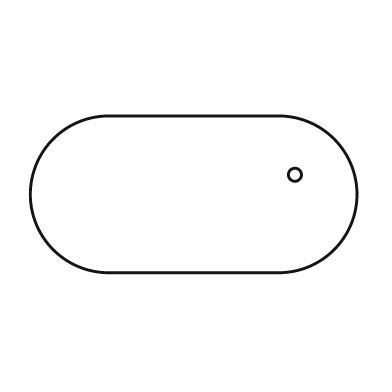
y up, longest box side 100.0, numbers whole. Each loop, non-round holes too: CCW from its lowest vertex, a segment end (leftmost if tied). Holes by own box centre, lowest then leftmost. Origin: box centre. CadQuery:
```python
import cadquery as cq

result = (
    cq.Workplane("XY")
    .moveTo(-26.0, -24.0)
    .lineTo(26.0, -24.0)
    .threePointArc((50.0, 0.0), (26.0, 24.0))
    .lineTo(-26.0, 24.0)
    .threePointArc((-50.0, 0.0), (-26.0, -24.0))
    .close()
    .moveTo(31.0, 6.0)
    .circle(2.0)
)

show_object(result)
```